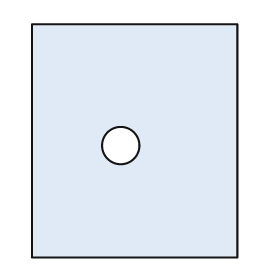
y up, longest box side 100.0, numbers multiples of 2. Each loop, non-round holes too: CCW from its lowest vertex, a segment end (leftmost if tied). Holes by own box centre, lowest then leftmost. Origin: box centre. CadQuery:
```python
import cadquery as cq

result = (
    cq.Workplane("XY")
    .moveTo(-44.0, -50.0)
    .lineTo(44.0, -50.0)
    .lineTo(44.0, 50.0)
    .lineTo(-44.0, 50.0)
    .close()
    .moveTo(-6.0, -2.0)
    .circle(8.0)
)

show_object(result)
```